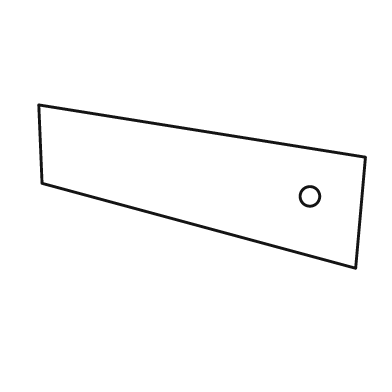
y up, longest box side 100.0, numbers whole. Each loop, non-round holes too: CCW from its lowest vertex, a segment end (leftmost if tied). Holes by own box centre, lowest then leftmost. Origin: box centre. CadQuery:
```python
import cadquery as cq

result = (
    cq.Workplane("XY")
    .moveTo(47.0, -25.0)
    .lineTo(50.0, 9.0)
    .lineTo(-50.0, 25.0)
    .lineTo(-49.0, 1.0)
    .close()
    .moveTo(33.0, -3.0)
    .circle(3.0)
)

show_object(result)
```